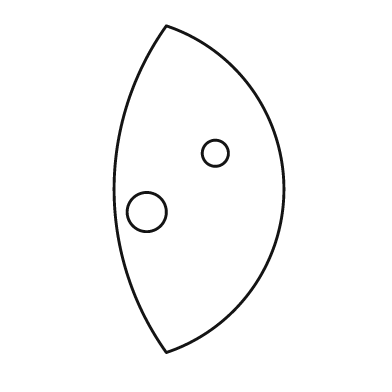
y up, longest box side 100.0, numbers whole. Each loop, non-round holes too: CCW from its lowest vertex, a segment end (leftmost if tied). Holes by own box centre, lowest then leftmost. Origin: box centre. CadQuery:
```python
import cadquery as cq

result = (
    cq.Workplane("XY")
    .moveTo(-10.0, -50.0)
    .threePointArc((26.0, 0.0), (-10.0, 50.0))
    .threePointArc((-26.0, 0.0), (-10.0, -50.0))
    .close()
    .moveTo(-16.0, -7.0)
    .circle(6.0)
    .moveTo(5.0, 11.0)
    .circle(4.0)
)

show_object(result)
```